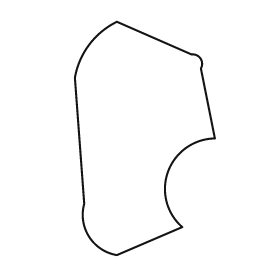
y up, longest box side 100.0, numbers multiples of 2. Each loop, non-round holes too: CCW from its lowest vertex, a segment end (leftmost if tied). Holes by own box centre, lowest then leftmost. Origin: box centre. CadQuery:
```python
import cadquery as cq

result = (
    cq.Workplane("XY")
    .moveTo(-12.0, -50.0)
    .lineTo(16.0, -38.0)
    .threePointArc((10.0, -14.0), (30.0, 0.0))
    .lineTo(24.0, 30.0)
    .threePointArc((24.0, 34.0), (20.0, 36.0))
    .lineTo(-12.0, 50.0)
    .threePointArc((-24.0, 40.0), (-30.0, 26.0))
    .lineTo(-26.0, -28.0)
    .threePointArc((-24.0, -42.0), (-12.0, -50.0))
    .close()
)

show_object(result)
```